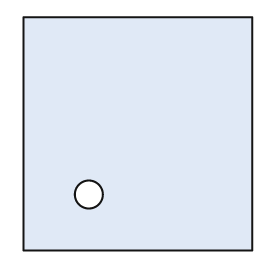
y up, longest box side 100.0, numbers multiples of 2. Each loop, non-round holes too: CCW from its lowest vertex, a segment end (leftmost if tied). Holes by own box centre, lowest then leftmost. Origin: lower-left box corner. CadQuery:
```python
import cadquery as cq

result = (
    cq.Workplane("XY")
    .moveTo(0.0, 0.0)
    .lineTo(98.0, 0.0)
    .lineTo(98.0, 100.0)
    .lineTo(0.0, 100.0)
    .close()
    .moveTo(28.0, 24.0)
    .circle(6.0)
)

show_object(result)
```